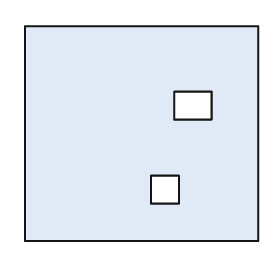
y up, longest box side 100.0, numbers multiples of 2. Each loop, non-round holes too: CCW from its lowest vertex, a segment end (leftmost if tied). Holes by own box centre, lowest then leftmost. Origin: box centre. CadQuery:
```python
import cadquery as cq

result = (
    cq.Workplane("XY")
    .moveTo(-50.0, -46.0)
    .lineTo(50.0, -46.0)
    .lineTo(50.0, 46.0)
    .lineTo(-50.0, 46.0)
    .close()
    .moveTo(4.0, -30.0)
    .lineTo(16.0, -30.0)
    .lineTo(16.0, -18.0)
    .lineTo(4.0, -18.0)
    .close()
    .moveTo(14.0, 6.0)
    .lineTo(30.0, 6.0)
    .lineTo(30.0, 18.0)
    .lineTo(14.0, 18.0)
    .close()
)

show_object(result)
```